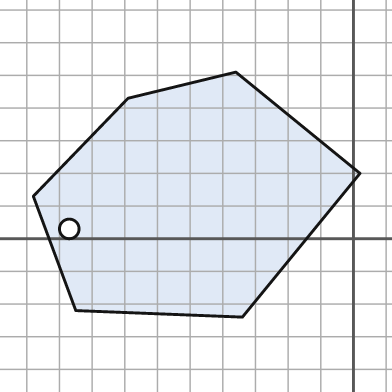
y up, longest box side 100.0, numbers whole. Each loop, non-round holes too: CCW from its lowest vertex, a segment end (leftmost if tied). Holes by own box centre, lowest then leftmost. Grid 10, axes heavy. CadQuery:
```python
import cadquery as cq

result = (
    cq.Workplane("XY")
    .moveTo(-34.0, -24.0)
    .lineTo(2.0, 20.0)
    .lineTo(-36.0, 51.0)
    .lineTo(-69.0, 43.0)
    .lineTo(-98.0, 13.0)
    .lineTo(-85.0, -22.0)
    .close()
    .moveTo(-87.0, 3.0)
    .circle(3.0)
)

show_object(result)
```